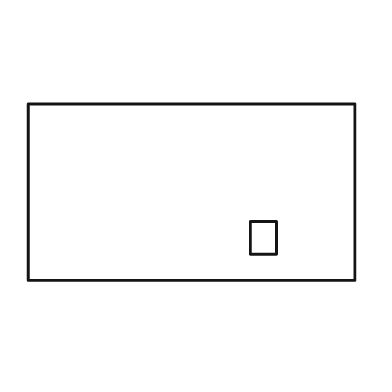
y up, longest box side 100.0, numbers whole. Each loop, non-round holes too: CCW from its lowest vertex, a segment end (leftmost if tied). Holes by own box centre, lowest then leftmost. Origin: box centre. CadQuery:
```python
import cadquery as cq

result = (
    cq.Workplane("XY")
    .moveTo(-50.0, -27.0)
    .lineTo(50.0, -27.0)
    .lineTo(50.0, 27.0)
    .lineTo(-50.0, 27.0)
    .close()
    .moveTo(18.0, -19.0)
    .lineTo(26.0, -19.0)
    .lineTo(26.0, -9.0)
    .lineTo(18.0, -9.0)
    .close()
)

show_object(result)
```